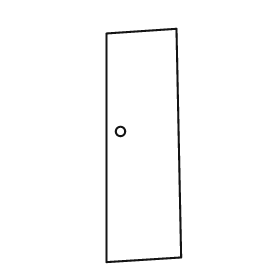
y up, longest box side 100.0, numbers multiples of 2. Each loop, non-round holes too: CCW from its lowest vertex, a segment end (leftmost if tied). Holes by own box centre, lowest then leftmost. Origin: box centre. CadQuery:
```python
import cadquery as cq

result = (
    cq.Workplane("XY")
    .moveTo(-16.0, -50.0)
    .lineTo(16.0, -48.0)
    .lineTo(14.0, 50.0)
    .lineTo(-16.0, 48.0)
    .close()
    .moveTo(-10.0, 6.0)
    .circle(2.0)
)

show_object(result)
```